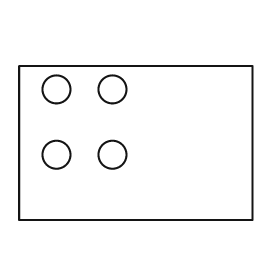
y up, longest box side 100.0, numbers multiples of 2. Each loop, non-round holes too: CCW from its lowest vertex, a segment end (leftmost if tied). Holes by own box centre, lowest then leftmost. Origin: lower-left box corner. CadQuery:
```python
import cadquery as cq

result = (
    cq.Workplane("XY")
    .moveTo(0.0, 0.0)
    .lineTo(100.0, 0.0)
    .lineTo(100.0, 66.0)
    .lineTo(0.0, 66.0)
    .close()
    .moveTo(16.0, 28.0)
    .circle(6.0)
    .moveTo(40.0, 28.0)
    .circle(6.0)
    .moveTo(16.0, 56.0)
    .circle(6.0)
    .moveTo(40.0, 56.0)
    .circle(6.0)
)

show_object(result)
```